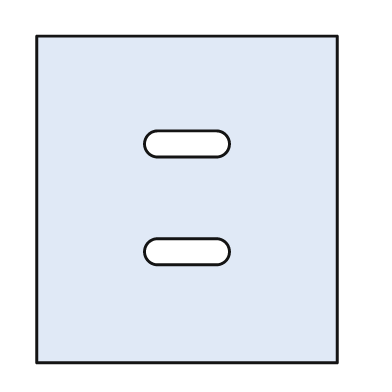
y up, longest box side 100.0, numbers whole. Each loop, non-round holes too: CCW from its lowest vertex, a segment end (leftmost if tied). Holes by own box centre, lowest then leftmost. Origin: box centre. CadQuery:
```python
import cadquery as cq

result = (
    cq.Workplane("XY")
    .moveTo(-46.0, -50.0)
    .lineTo(46.0, -50.0)
    .lineTo(46.0, 50.0)
    .lineTo(-46.0, 50.0)
    .close()
    .moveTo(-9.0, -20.0)
    .lineTo(9.0, -20.0)
    .threePointArc((13.0, -16.0), (9.0, -12.0))
    .lineTo(-9.0, -12.0)
    .threePointArc((-13.0, -16.0), (-9.0, -20.0))
    .close()
    .moveTo(-9.0, 13.0)
    .lineTo(9.0, 13.0)
    .threePointArc((13.0, 17.0), (9.0, 21.0))
    .lineTo(-9.0, 21.0)
    .threePointArc((-13.0, 17.0), (-9.0, 13.0))
    .close()
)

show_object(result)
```